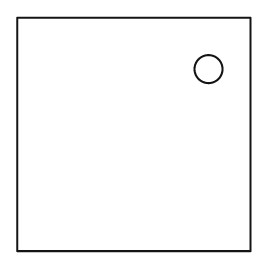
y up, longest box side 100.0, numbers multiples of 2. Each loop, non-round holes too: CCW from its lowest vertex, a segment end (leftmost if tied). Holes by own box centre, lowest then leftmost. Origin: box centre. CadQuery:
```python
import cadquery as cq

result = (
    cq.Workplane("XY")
    .moveTo(-50.0, -50.0)
    .lineTo(50.0, -50.0)
    .lineTo(50.0, 50.0)
    .lineTo(-50.0, 50.0)
    .close()
    .moveTo(32.0, 28.0)
    .circle(6.0)
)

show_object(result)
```